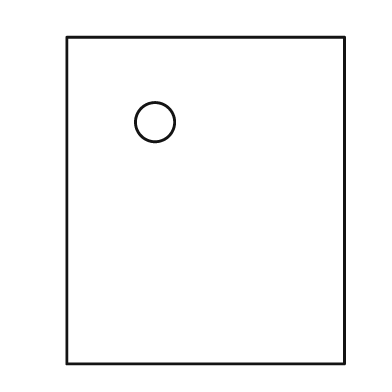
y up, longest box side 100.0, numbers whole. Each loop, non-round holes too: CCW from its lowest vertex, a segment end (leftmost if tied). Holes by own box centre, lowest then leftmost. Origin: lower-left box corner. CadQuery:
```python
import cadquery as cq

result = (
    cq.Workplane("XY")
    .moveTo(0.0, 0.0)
    .lineTo(85.0, 0.0)
    .lineTo(85.0, 100.0)
    .lineTo(0.0, 100.0)
    .close()
    .moveTo(27.0, 74.0)
    .circle(6.0)
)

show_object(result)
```